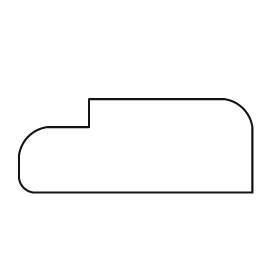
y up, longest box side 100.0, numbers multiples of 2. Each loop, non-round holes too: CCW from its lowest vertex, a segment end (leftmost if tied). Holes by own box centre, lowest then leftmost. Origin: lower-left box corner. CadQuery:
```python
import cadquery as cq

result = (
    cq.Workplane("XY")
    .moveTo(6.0, 0.0)
    .lineTo(100.0, 0.0)
    .lineTo(100.0, 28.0)
    .threePointArc((96.0, 36.0), (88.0, 40.0))
    .lineTo(30.0, 40.0)
    .lineTo(30.0, 28.0)
    .lineTo(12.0, 28.0)
    .threePointArc((4.0, 24.0), (0.0, 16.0))
    .lineTo(0.0, 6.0)
    .threePointArc((2.0, 2.0), (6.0, 0.0))
    .close()
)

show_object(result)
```